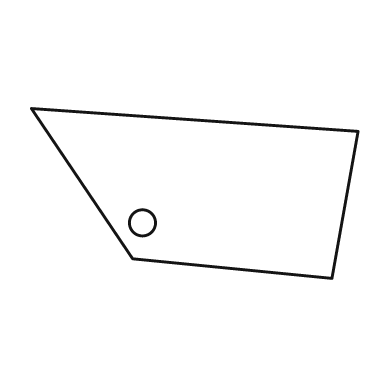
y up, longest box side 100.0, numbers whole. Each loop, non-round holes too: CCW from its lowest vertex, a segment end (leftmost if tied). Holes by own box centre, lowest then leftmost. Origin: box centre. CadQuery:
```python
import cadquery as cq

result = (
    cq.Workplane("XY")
    .moveTo(42.0, -26.0)
    .lineTo(50.0, 19.0)
    .lineTo(-50.0, 26.0)
    .lineTo(-19.0, -20.0)
    .close()
    .moveTo(-16.0, -9.0)
    .circle(4.0)
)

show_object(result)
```